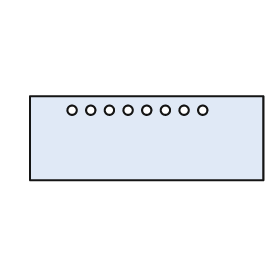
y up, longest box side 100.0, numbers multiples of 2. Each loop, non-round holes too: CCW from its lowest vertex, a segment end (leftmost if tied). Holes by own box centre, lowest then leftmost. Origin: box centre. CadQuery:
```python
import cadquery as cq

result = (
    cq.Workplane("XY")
    .moveTo(-50.0, -18.0)
    .lineTo(50.0, -18.0)
    .lineTo(50.0, 18.0)
    .lineTo(-50.0, 18.0)
    .close()
    .moveTo(-32.0, 12.0)
    .circle(2.0)
    .moveTo(-24.0, 12.0)
    .circle(2.0)
    .moveTo(-16.0, 12.0)
    .circle(2.0)
    .moveTo(-8.0, 12.0)
    .circle(2.0)
    .moveTo(0.0, 12.0)
    .circle(2.0)
    .moveTo(8.0, 12.0)
    .circle(2.0)
    .moveTo(16.0, 12.0)
    .circle(2.0)
    .moveTo(24.0, 12.0)
    .circle(2.0)
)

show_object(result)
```